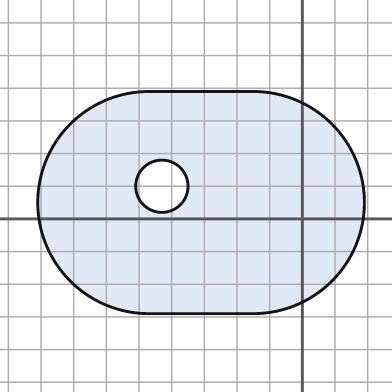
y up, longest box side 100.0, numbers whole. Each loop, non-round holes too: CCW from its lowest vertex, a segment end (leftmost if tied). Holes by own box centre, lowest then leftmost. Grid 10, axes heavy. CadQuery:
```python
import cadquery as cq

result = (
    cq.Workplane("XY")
    .moveTo(-47.0, -29.0)
    .lineTo(-15.0, -29.0)
    .threePointArc((19.0, 5.0), (-15.0, 39.0))
    .lineTo(-47.0, 39.0)
    .threePointArc((-81.0, 5.0), (-47.0, -29.0))
    .close()
    .moveTo(-43.0, 10.0)
    .circle(8.0)
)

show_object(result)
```